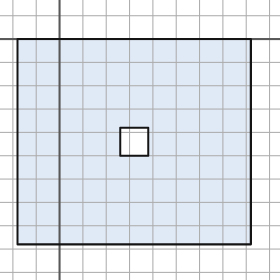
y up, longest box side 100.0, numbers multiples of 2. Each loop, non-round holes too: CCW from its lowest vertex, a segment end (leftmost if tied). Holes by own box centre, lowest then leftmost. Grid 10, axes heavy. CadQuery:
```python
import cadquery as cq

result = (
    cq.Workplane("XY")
    .moveTo(-18.0, -88.0)
    .lineTo(82.0, -88.0)
    .lineTo(82.0, 0.0)
    .lineTo(-18.0, 0.0)
    .close()
    .moveTo(26.0, -50.0)
    .lineTo(38.0, -50.0)
    .lineTo(38.0, -38.0)
    .lineTo(26.0, -38.0)
    .close()
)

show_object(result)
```